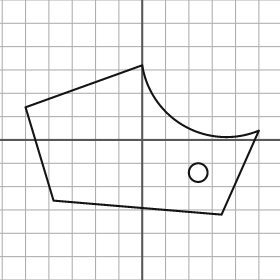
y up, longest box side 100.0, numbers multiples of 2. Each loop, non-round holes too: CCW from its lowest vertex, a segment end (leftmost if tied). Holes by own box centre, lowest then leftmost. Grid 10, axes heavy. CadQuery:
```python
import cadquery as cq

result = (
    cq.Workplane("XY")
    .moveTo(34.0, -32.0)
    .lineTo(50.0, 4.0)
    .threePointArc((18.0, 6.0), (0.0, 32.0))
    .lineTo(-50.0, 14.0)
    .lineTo(-38.0, -26.0)
    .close()
    .moveTo(24.0, -14.0)
    .circle(4.0)
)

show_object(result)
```